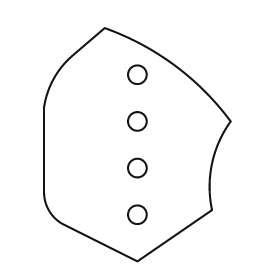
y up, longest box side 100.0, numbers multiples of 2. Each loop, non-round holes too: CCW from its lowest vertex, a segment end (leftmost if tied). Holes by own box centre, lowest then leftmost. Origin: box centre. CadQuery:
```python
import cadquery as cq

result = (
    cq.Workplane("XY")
    .moveTo(0.0, -50.0)
    .lineTo(32.0, -28.0)
    .threePointArc((32.0, -8.0), (40.0, 10.0))
    .threePointArc((16.0, 34.0), (-14.0, 50.0))
    .lineTo(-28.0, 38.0)
    .threePointArc((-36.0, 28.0), (-40.0, 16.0))
    .lineTo(-40.0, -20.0)
    .threePointArc((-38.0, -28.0), (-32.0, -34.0))
    .close()
    .moveTo(0.0, -30.0)
    .circle(4.0)
    .moveTo(0.0, -10.0)
    .circle(4.0)
    .moveTo(0.0, 10.0)
    .circle(4.0)
    .moveTo(0.0, 30.0)
    .circle(4.0)
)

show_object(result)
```